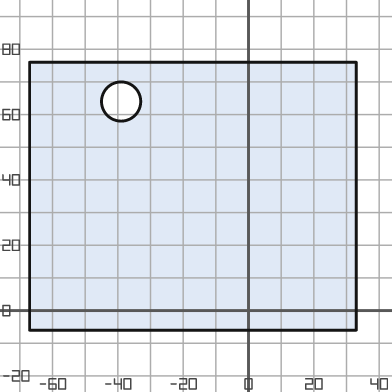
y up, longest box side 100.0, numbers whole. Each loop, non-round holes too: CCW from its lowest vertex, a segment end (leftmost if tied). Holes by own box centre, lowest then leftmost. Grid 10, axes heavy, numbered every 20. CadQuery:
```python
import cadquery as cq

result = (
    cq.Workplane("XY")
    .moveTo(-67.0, -6.0)
    .lineTo(33.0, -6.0)
    .lineTo(33.0, 76.0)
    .lineTo(-67.0, 76.0)
    .close()
    .moveTo(-39.0, 64.0)
    .circle(6.0)
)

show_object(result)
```